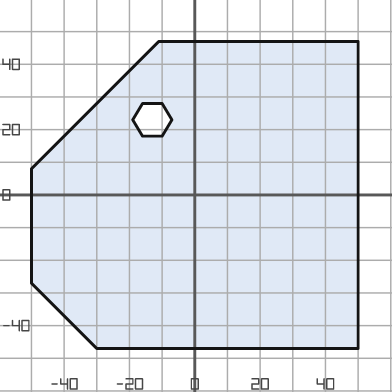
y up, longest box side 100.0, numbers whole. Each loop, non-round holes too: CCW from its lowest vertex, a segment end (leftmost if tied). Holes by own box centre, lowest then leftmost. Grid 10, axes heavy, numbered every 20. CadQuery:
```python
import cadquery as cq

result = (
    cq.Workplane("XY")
    .moveTo(-30.0, -47.0)
    .lineTo(50.0, -47.0)
    .lineTo(50.0, 47.0)
    .lineTo(-11.0, 47.0)
    .lineTo(-50.0, 8.0)
    .lineTo(-50.0, -27.0)
    .close()
    .moveTo(-16.0, 18.0)
    .lineTo(-10.0, 18.0)
    .lineTo(-7.0, 23.0)
    .lineTo(-10.0, 28.0)
    .lineTo(-16.0, 28.0)
    .lineTo(-19.0, 23.0)
    .close()
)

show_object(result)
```